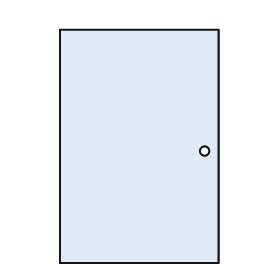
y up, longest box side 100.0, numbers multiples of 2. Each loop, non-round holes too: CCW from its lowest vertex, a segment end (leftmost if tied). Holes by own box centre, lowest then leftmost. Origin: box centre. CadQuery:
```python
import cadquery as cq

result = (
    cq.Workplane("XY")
    .moveTo(-34.0, -50.0)
    .lineTo(34.0, -50.0)
    .lineTo(34.0, 50.0)
    .lineTo(-34.0, 50.0)
    .close()
    .moveTo(28.0, -2.0)
    .circle(2.0)
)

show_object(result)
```